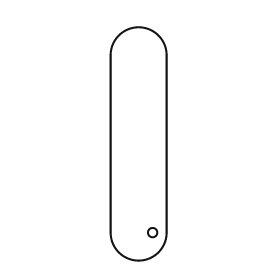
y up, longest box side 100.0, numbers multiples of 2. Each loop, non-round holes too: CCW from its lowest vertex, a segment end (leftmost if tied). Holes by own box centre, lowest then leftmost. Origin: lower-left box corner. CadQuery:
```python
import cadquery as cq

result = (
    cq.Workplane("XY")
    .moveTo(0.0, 12.0)
    .threePointArc((12.0, 0.0), (24.0, 12.0))
    .lineTo(24.0, 88.0)
    .threePointArc((12.0, 100.0), (0.0, 88.0))
    .close()
    .moveTo(18.0, 12.0)
    .circle(2.0)
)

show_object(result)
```